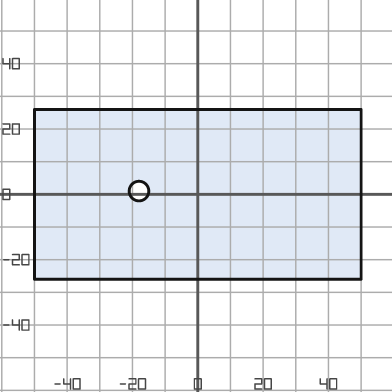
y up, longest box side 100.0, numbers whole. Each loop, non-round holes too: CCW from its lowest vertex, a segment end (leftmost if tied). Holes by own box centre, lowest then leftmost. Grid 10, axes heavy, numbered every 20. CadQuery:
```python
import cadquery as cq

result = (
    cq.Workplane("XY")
    .moveTo(-50.0, -26.0)
    .lineTo(50.0, -26.0)
    .lineTo(50.0, 26.0)
    .lineTo(-50.0, 26.0)
    .close()
    .moveTo(-18.0, 1.0)
    .circle(3.0)
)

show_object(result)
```